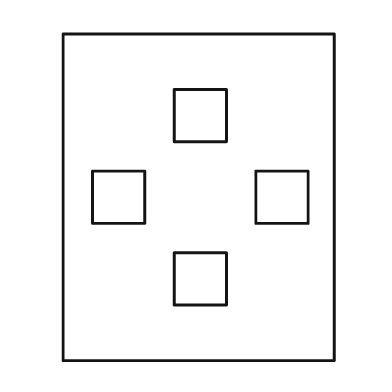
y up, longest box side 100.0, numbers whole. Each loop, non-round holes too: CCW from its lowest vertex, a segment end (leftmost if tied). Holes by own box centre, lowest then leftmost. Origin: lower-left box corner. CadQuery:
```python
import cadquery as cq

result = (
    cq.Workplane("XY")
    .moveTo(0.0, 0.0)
    .lineTo(83.0, 0.0)
    .lineTo(83.0, 100.0)
    .lineTo(0.0, 100.0)
    .close()
    .moveTo(34.0, 17.0)
    .lineTo(50.0, 17.0)
    .lineTo(50.0, 33.0)
    .lineTo(34.0, 33.0)
    .close()
    .moveTo(9.0, 42.0)
    .lineTo(25.0, 42.0)
    .lineTo(25.0, 58.0)
    .lineTo(9.0, 58.0)
    .close()
    .moveTo(59.0, 42.0)
    .lineTo(75.0, 42.0)
    .lineTo(75.0, 58.0)
    .lineTo(59.0, 58.0)
    .close()
    .moveTo(34.0, 67.0)
    .lineTo(50.0, 67.0)
    .lineTo(50.0, 83.0)
    .lineTo(34.0, 83.0)
    .close()
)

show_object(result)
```